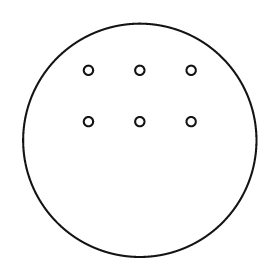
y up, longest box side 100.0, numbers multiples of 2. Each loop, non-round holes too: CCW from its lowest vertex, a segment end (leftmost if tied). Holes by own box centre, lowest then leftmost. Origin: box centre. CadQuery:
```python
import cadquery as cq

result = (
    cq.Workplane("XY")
    .moveTo(0.0, 0.0)
    .circle(50.0)
    .moveTo(-22.0, 8.0)
    .circle(2.0)
    .moveTo(0.0, 8.0)
    .circle(2.0)
    .moveTo(22.0, 8.0)
    .circle(2.0)
    .moveTo(-22.0, 30.0)
    .circle(2.0)
    .moveTo(0.0, 30.0)
    .circle(2.0)
    .moveTo(22.0, 30.0)
    .circle(2.0)
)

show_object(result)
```